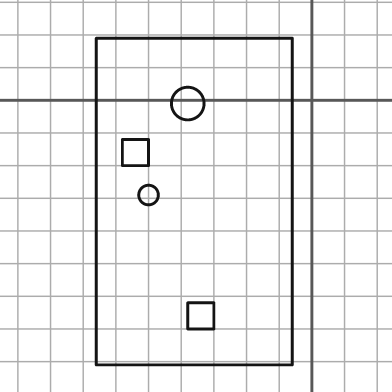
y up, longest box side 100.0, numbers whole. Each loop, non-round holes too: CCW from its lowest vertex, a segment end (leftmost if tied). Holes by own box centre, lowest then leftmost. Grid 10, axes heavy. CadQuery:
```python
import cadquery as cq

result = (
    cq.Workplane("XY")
    .moveTo(-66.0, -81.0)
    .lineTo(-6.0, -81.0)
    .lineTo(-6.0, 19.0)
    .lineTo(-66.0, 19.0)
    .close()
    .moveTo(-38.0, -70.0)
    .lineTo(-30.0, -70.0)
    .lineTo(-30.0, -62.0)
    .lineTo(-38.0, -62.0)
    .close()
    .moveTo(-50.0, -29.0)
    .circle(3.0)
    .moveTo(-58.0, -20.0)
    .lineTo(-50.0, -20.0)
    .lineTo(-50.0, -12.0)
    .lineTo(-58.0, -12.0)
    .close()
    .moveTo(-38.0, -1.0)
    .circle(5.0)
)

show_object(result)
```